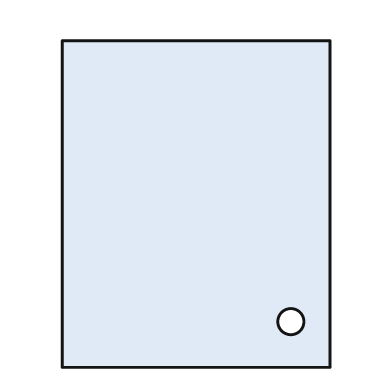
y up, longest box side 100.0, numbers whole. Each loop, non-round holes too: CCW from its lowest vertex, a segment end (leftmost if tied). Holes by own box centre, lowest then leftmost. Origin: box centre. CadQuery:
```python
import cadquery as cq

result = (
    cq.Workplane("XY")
    .moveTo(-41.0, -50.0)
    .lineTo(41.0, -50.0)
    .lineTo(41.0, 50.0)
    .lineTo(-41.0, 50.0)
    .close()
    .moveTo(29.0, -36.0)
    .circle(4.0)
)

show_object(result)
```